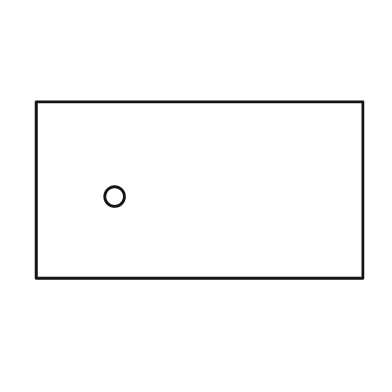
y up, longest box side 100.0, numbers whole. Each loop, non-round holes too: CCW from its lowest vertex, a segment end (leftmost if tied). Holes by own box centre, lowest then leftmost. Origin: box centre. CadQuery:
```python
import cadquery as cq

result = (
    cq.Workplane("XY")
    .moveTo(-50.0, -27.0)
    .lineTo(50.0, -27.0)
    .lineTo(50.0, 27.0)
    .lineTo(-50.0, 27.0)
    .close()
    .moveTo(-26.0, -2.0)
    .circle(3.0)
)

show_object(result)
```